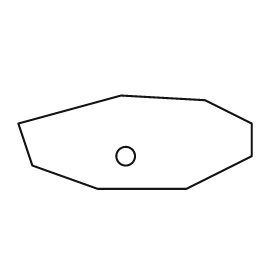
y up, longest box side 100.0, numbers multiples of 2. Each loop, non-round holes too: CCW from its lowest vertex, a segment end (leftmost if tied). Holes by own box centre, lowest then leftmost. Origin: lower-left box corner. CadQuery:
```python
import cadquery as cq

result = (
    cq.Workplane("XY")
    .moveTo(34.0, 0.0)
    .lineTo(72.0, 0.0)
    .lineTo(100.0, 14.0)
    .lineTo(100.0, 28.0)
    .lineTo(80.0, 38.0)
    .lineTo(44.0, 40.0)
    .lineTo(0.0, 28.0)
    .lineTo(6.0, 10.0)
    .close()
    .moveTo(46.0, 14.0)
    .circle(4.0)
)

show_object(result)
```